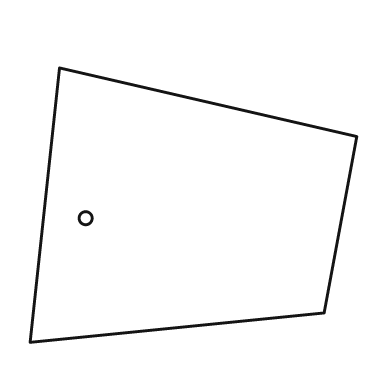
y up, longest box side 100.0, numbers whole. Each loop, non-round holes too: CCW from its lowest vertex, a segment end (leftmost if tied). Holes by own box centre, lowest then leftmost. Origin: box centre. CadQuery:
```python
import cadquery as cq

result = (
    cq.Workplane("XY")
    .moveTo(-50.0, -42.0)
    .lineTo(40.0, -33.0)
    .lineTo(50.0, 21.0)
    .lineTo(-41.0, 42.0)
    .close()
    .moveTo(-33.0, -4.0)
    .circle(2.0)
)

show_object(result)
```